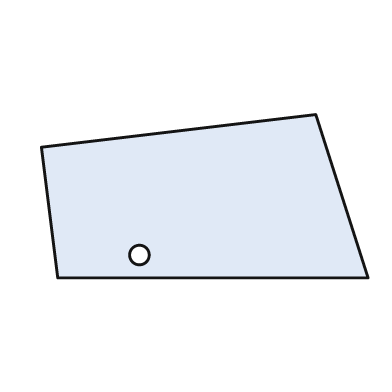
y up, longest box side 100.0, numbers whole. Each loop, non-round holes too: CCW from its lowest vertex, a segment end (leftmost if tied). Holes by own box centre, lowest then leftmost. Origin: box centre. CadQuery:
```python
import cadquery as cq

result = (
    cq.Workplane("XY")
    .moveTo(-45.0, -25.0)
    .lineTo(50.0, -25.0)
    .lineTo(34.0, 25.0)
    .lineTo(-50.0, 15.0)
    .close()
    .moveTo(-20.0, -18.0)
    .circle(3.0)
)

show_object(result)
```